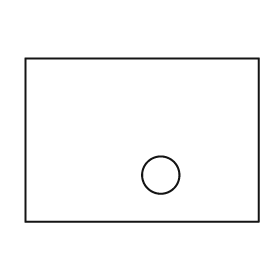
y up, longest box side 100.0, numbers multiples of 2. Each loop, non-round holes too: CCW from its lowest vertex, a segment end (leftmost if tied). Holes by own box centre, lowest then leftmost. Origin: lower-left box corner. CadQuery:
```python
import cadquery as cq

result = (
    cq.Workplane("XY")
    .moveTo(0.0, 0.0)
    .lineTo(100.0, 0.0)
    .lineTo(100.0, 70.0)
    .lineTo(0.0, 70.0)
    .close()
    .moveTo(58.0, 20.0)
    .circle(8.0)
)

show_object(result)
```